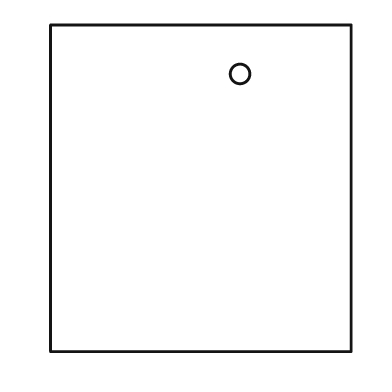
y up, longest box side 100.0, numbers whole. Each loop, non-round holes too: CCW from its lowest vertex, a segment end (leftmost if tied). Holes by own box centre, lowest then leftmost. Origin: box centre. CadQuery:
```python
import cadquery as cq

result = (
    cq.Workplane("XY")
    .moveTo(-46.0, -50.0)
    .lineTo(46.0, -50.0)
    .lineTo(46.0, 50.0)
    .lineTo(-46.0, 50.0)
    .close()
    .moveTo(12.0, 35.0)
    .circle(3.0)
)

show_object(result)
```